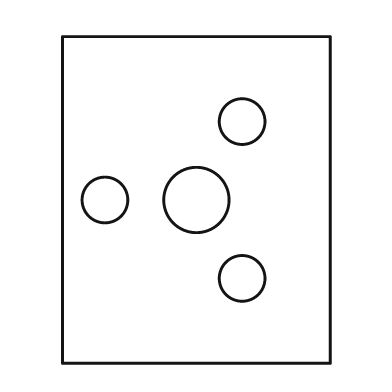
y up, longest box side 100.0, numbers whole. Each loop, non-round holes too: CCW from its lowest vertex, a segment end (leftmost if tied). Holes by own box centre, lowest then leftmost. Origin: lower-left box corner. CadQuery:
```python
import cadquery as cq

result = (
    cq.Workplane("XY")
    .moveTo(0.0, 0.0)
    .lineTo(82.0, 0.0)
    .lineTo(82.0, 100.0)
    .lineTo(0.0, 100.0)
    .close()
    .moveTo(55.0, 26.0)
    .circle(7.0)
    .moveTo(13.0, 50.0)
    .circle(7.0)
    .moveTo(41.0, 50.0)
    .circle(10.0)
    .moveTo(55.0, 74.0)
    .circle(7.0)
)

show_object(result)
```